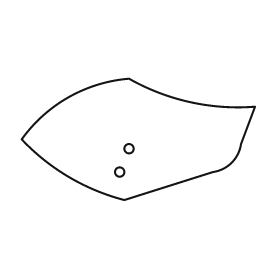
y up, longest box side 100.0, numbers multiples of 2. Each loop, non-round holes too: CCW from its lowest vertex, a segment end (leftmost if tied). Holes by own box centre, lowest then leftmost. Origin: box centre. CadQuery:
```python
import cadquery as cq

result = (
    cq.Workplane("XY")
    .moveTo(-6.0, -26.0)
    .lineTo(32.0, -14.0)
    .threePointArc((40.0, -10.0), (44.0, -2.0))
    .lineTo(50.0, 14.0)
    .threePointArc((22.0, 16.0), (-4.0, 26.0))
    .threePointArc((-30.0, 18.0), (-50.0, 0.0))
    .threePointArc((-30.0, -16.0), (-6.0, -26.0))
    .close()
    .moveTo(-8.0, -14.0)
    .circle(2.0)
    .moveTo(-4.0, -4.0)
    .circle(2.0)
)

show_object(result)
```